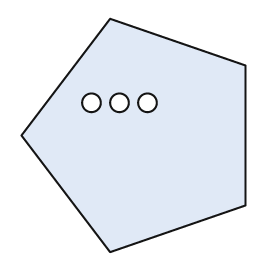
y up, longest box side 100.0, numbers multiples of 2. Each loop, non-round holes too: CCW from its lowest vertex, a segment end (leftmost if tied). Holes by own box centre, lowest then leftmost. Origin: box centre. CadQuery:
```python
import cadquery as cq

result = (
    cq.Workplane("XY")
    .moveTo(-10.0, -50.0)
    .lineTo(48.0, -30.0)
    .lineTo(48.0, 30.0)
    .lineTo(-10.0, 50.0)
    .lineTo(-48.0, 0.0)
    .close()
    .moveTo(-18.0, 14.0)
    .circle(4.0)
    .moveTo(-6.0, 14.0)
    .circle(4.0)
    .moveTo(6.0, 14.0)
    .circle(4.0)
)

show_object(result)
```